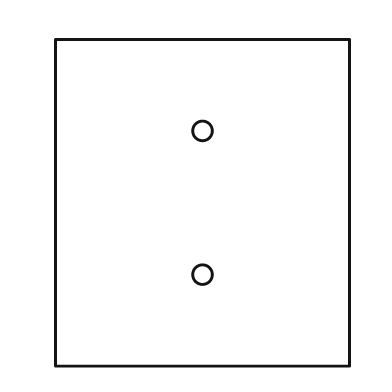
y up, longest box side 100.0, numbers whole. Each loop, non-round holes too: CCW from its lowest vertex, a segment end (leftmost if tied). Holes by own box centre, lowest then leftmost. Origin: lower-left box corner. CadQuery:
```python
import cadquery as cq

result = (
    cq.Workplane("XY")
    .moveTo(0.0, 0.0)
    .lineTo(90.0, 0.0)
    .lineTo(90.0, 100.0)
    .lineTo(0.0, 100.0)
    .close()
    .moveTo(45.0, 28.0)
    .circle(3.0)
    .moveTo(45.0, 72.0)
    .circle(3.0)
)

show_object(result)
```